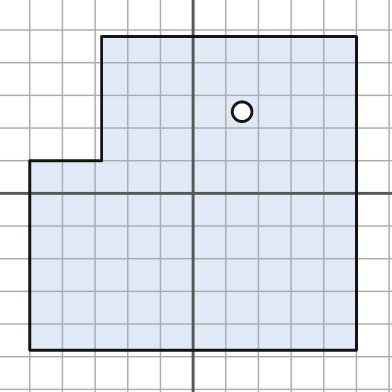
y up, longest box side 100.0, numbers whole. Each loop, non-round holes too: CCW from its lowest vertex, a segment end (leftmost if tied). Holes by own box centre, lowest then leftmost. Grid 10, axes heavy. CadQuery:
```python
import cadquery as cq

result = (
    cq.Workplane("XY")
    .moveTo(-50.0, -48.0)
    .lineTo(50.0, -48.0)
    .lineTo(50.0, 48.0)
    .lineTo(-28.0, 48.0)
    .lineTo(-28.0, 10.0)
    .lineTo(-50.0, 10.0)
    .close()
    .moveTo(15.0, 25.0)
    .circle(3.0)
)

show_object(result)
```